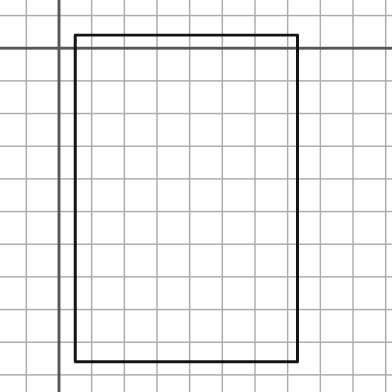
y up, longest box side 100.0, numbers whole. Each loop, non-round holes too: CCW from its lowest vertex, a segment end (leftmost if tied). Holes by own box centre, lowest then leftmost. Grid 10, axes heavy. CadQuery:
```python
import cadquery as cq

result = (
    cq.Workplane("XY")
    .moveTo(5.0, -96.0)
    .lineTo(73.0, -96.0)
    .lineTo(73.0, 4.0)
    .lineTo(5.0, 4.0)
    .close()
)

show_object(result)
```